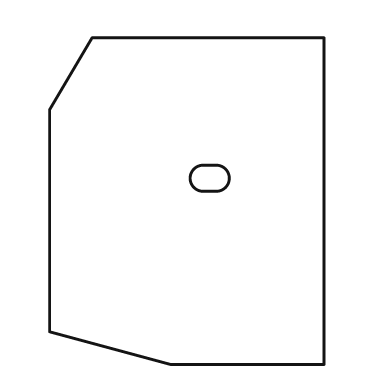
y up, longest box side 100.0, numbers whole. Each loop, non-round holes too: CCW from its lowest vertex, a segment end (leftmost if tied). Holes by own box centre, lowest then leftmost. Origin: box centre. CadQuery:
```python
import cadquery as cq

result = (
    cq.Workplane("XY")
    .moveTo(-5.0, -50.0)
    .lineTo(42.0, -50.0)
    .lineTo(42.0, 50.0)
    .lineTo(-29.0, 50.0)
    .lineTo(-42.0, 28.0)
    .lineTo(-42.0, -40.0)
    .close()
    .moveTo(5.0, 3.0)
    .lineTo(9.0, 3.0)
    .threePointArc((13.0, 7.0), (9.0, 11.0))
    .lineTo(5.0, 11.0)
    .threePointArc((1.0, 7.0), (5.0, 3.0))
    .close()
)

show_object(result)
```